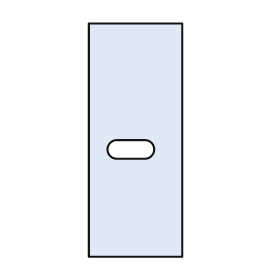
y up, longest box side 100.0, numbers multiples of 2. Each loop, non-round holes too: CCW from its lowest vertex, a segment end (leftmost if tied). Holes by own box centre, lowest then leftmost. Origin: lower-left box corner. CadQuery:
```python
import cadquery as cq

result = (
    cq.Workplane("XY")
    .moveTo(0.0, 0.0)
    .lineTo(40.0, 0.0)
    .lineTo(40.0, 100.0)
    .lineTo(0.0, 100.0)
    .close()
    .moveTo(12.0, 42.0)
    .lineTo(24.0, 42.0)
    .threePointArc((28.0, 46.0), (24.0, 50.0))
    .lineTo(12.0, 50.0)
    .threePointArc((8.0, 46.0), (12.0, 42.0))
    .close()
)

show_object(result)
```